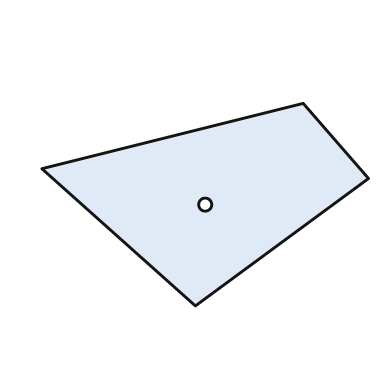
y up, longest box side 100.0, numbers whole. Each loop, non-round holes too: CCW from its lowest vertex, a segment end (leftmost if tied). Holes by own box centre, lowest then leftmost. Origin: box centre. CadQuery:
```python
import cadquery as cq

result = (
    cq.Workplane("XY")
    .moveTo(-3.0, -31.0)
    .lineTo(50.0, 8.0)
    .lineTo(30.0, 31.0)
    .lineTo(-50.0, 11.0)
    .close()
    .moveTo(0.0, 0.0)
    .circle(2.0)
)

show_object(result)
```